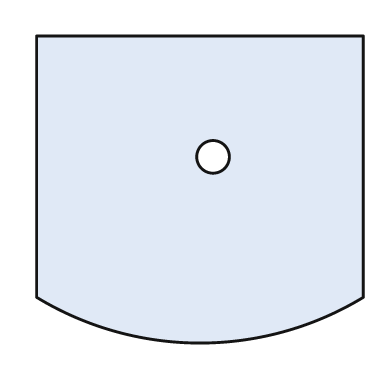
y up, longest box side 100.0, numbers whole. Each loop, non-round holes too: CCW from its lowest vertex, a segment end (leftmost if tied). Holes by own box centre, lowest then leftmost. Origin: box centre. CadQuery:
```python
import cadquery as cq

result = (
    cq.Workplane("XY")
    .moveTo(-50.0, -33.0)
    .threePointArc((0.0, -47.0), (50.0, -33.0))
    .lineTo(50.0, 47.0)
    .lineTo(-50.0, 47.0)
    .close()
    .moveTo(4.0, 10.0)
    .circle(5.0)
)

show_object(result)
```